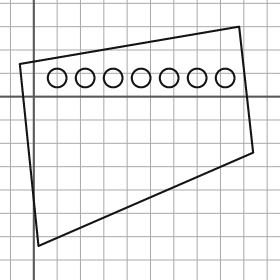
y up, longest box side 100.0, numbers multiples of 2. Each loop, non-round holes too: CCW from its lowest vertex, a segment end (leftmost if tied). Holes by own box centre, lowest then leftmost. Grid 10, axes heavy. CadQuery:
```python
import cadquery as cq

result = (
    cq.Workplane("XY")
    .moveTo(2.0, -64.0)
    .lineTo(94.0, -24.0)
    .lineTo(88.0, 30.0)
    .lineTo(-6.0, 14.0)
    .close()
    .moveTo(10.0, 8.0)
    .circle(4.0)
    .moveTo(22.0, 8.0)
    .circle(4.0)
    .moveTo(34.0, 8.0)
    .circle(4.0)
    .moveTo(46.0, 8.0)
    .circle(4.0)
    .moveTo(58.0, 8.0)
    .circle(4.0)
    .moveTo(70.0, 8.0)
    .circle(4.0)
    .moveTo(82.0, 8.0)
    .circle(4.0)
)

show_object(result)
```